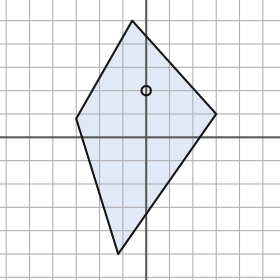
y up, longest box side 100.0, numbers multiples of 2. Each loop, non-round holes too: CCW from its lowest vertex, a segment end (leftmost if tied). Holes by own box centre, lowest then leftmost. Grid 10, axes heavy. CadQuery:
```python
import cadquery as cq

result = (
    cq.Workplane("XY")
    .moveTo(-12.0, -50.0)
    .lineTo(30.0, 10.0)
    .lineTo(-6.0, 50.0)
    .lineTo(-30.0, 8.0)
    .close()
    .moveTo(0.0, 20.0)
    .circle(2.0)
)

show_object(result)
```